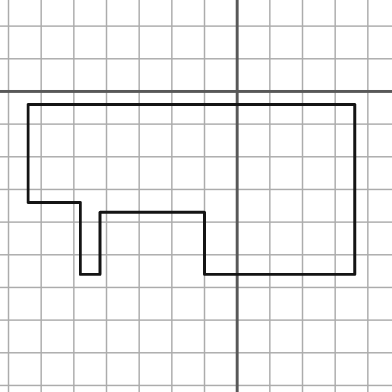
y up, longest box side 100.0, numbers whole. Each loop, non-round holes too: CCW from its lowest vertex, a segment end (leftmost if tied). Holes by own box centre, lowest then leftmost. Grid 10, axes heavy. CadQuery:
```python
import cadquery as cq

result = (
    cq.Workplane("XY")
    .moveTo(-48.0, -56.0)
    .lineTo(-42.0, -56.0)
    .lineTo(-42.0, -37.0)
    .lineTo(-10.0, -37.0)
    .lineTo(-10.0, -56.0)
    .lineTo(36.0, -56.0)
    .lineTo(36.0, -4.0)
    .lineTo(-64.0, -4.0)
    .lineTo(-64.0, -34.0)
    .lineTo(-48.0, -34.0)
    .close()
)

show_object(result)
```